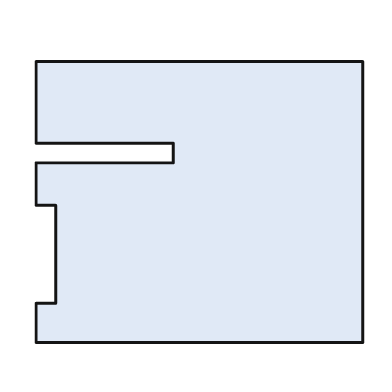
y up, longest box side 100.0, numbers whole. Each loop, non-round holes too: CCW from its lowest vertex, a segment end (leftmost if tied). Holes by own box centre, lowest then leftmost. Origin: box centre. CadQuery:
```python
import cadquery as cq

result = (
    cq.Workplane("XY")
    .moveTo(-50.0, -43.0)
    .lineTo(50.0, -43.0)
    .lineTo(50.0, 43.0)
    .lineTo(-50.0, 43.0)
    .lineTo(-50.0, 18.0)
    .lineTo(-8.0, 18.0)
    .lineTo(-8.0, 12.0)
    .lineTo(-50.0, 12.0)
    .lineTo(-50.0, -1.0)
    .lineTo(-44.0, -1.0)
    .lineTo(-44.0, -31.0)
    .lineTo(-50.0, -31.0)
    .close()
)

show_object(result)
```